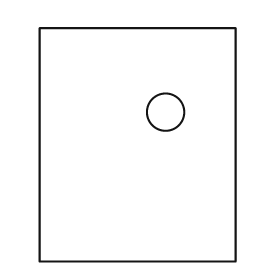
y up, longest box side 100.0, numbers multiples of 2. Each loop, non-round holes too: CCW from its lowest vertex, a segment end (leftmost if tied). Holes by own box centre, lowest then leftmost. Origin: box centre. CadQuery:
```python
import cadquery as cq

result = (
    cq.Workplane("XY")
    .moveTo(-42.0, -50.0)
    .lineTo(42.0, -50.0)
    .lineTo(42.0, 50.0)
    .lineTo(-42.0, 50.0)
    .close()
    .moveTo(12.0, 14.0)
    .circle(8.0)
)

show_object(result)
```